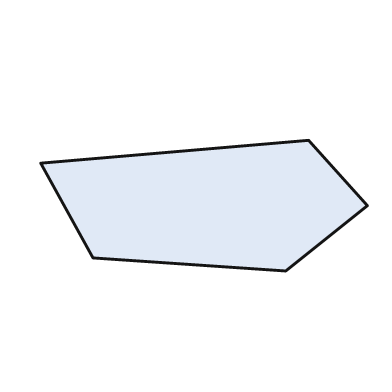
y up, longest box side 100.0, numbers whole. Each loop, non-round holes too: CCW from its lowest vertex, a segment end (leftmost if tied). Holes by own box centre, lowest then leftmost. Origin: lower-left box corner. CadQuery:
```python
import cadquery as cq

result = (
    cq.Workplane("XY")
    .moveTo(75.0, 0.0)
    .lineTo(100.0, 20.0)
    .lineTo(82.0, 40.0)
    .lineTo(0.0, 33.0)
    .lineTo(16.0, 4.0)
    .close()
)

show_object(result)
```